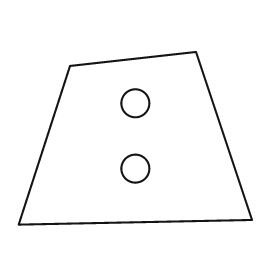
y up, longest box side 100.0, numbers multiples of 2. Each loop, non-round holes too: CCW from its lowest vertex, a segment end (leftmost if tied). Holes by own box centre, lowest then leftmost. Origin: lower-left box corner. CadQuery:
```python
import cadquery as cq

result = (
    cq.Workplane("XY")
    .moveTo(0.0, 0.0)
    .lineTo(100.0, 2.0)
    .lineTo(76.0, 74.0)
    .lineTo(22.0, 68.0)
    .close()
    .moveTo(50.0, 24.0)
    .circle(6.0)
    .moveTo(50.0, 52.0)
    .circle(6.0)
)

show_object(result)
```